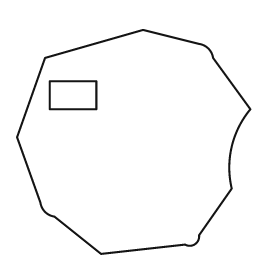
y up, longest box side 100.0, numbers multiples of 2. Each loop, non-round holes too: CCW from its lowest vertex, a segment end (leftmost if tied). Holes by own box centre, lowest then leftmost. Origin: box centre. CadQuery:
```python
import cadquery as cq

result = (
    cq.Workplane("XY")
    .moveTo(-14.0, -48.0)
    .lineTo(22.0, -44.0)
    .threePointArc((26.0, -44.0), (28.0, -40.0))
    .lineTo(42.0, -20.0)
    .threePointArc((42.0, -2.0), (50.0, 14.0))
    .lineTo(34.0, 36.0)
    .threePointArc((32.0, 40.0), (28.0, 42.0))
    .lineTo(4.0, 48.0)
    .lineTo(-38.0, 36.0)
    .lineTo(-50.0, 2.0)
    .lineTo(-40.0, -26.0)
    .threePointArc((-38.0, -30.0), (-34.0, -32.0))
    .close()
    .moveTo(-36.0, 14.0)
    .lineTo(-16.0, 14.0)
    .lineTo(-16.0, 26.0)
    .lineTo(-36.0, 26.0)
    .close()
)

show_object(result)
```